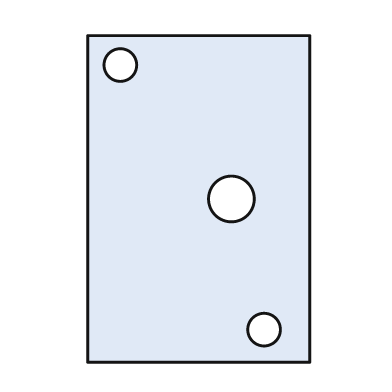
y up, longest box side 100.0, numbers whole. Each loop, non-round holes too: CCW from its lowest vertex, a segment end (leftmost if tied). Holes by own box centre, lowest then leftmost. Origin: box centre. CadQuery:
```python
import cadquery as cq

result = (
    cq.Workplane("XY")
    .moveTo(-34.0, -50.0)
    .lineTo(34.0, -50.0)
    .lineTo(34.0, 50.0)
    .lineTo(-34.0, 50.0)
    .close()
    .moveTo(20.0, -40.0)
    .circle(5.0)
    .moveTo(10.0, 0.0)
    .circle(7.0)
    .moveTo(-24.0, 41.0)
    .circle(5.0)
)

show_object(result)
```